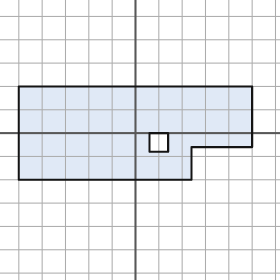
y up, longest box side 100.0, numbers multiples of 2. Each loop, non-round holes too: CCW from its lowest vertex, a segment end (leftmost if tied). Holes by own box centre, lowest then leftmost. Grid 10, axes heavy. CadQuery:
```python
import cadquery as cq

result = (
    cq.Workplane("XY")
    .moveTo(-50.0, -20.0)
    .lineTo(24.0, -20.0)
    .lineTo(24.0, -6.0)
    .lineTo(50.0, -6.0)
    .lineTo(50.0, 20.0)
    .lineTo(-50.0, 20.0)
    .close()
    .moveTo(6.0, -8.0)
    .lineTo(14.0, -8.0)
    .lineTo(14.0, 0.0)
    .lineTo(6.0, 0.0)
    .close()
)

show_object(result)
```